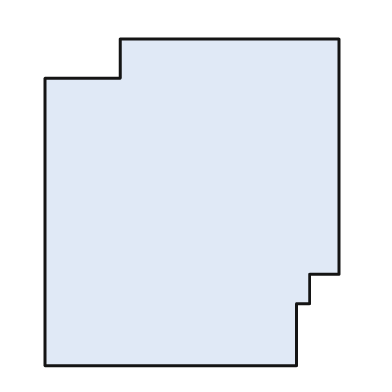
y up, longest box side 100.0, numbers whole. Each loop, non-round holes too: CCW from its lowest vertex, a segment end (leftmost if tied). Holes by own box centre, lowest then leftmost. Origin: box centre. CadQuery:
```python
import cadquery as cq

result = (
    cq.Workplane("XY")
    .moveTo(-45.0, -50.0)
    .lineTo(32.0, -50.0)
    .lineTo(32.0, -31.0)
    .lineTo(36.0, -31.0)
    .lineTo(36.0, -22.0)
    .lineTo(45.0, -22.0)
    .lineTo(45.0, 50.0)
    .lineTo(-22.0, 50.0)
    .lineTo(-22.0, 38.0)
    .lineTo(-45.0, 38.0)
    .close()
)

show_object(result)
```